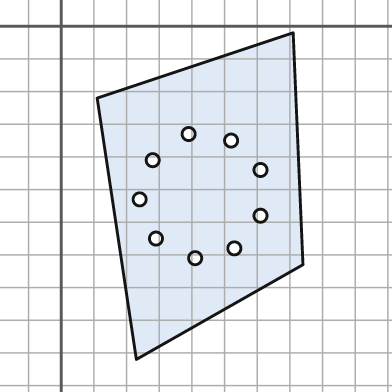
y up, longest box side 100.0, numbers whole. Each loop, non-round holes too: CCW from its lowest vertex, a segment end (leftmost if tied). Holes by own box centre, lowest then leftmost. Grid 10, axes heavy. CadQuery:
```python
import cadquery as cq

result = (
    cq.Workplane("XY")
    .moveTo(23.0, -102.0)
    .lineTo(74.0, -73.0)
    .lineTo(71.0, -2.0)
    .lineTo(11.0, -22.0)
    .close()
    .moveTo(41.0, -71.0)
    .circle(2.0)
    .moveTo(53.0, -68.0)
    .circle(2.0)
    .moveTo(29.0, -65.0)
    .circle(2.0)
    .moveTo(61.0, -58.0)
    .circle(2.0)
    .moveTo(24.0, -53.0)
    .circle(2.0)
    .moveTo(61.0, -44.0)
    .circle(2.0)
    .moveTo(28.0, -41.0)
    .circle(2.0)
    .moveTo(52.0, -35.0)
    .circle(2.0)
    .moveTo(39.0, -33.0)
    .circle(2.0)
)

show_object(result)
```